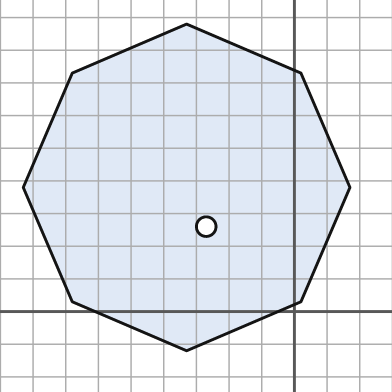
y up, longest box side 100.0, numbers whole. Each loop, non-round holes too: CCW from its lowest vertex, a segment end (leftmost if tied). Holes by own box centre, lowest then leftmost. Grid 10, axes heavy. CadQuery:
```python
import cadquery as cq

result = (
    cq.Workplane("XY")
    .moveTo(-33.0, -12.0)
    .lineTo(2.0, 3.0)
    .lineTo(17.0, 38.0)
    .lineTo(2.0, 73.0)
    .lineTo(-33.0, 88.0)
    .lineTo(-68.0, 73.0)
    .lineTo(-83.0, 38.0)
    .lineTo(-68.0, 3.0)
    .close()
    .moveTo(-27.0, 26.0)
    .circle(3.0)
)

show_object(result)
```